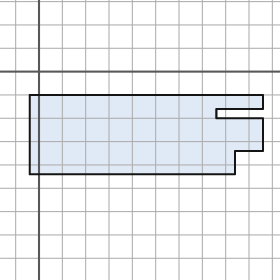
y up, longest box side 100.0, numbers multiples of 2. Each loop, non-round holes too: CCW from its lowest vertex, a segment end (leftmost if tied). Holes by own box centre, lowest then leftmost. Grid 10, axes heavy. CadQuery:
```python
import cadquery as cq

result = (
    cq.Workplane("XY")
    .moveTo(-4.0, -44.0)
    .lineTo(84.0, -44.0)
    .lineTo(84.0, -34.0)
    .lineTo(96.0, -34.0)
    .lineTo(96.0, -20.0)
    .lineTo(76.0, -20.0)
    .lineTo(76.0, -16.0)
    .lineTo(96.0, -16.0)
    .lineTo(96.0, -10.0)
    .lineTo(-4.0, -10.0)
    .close()
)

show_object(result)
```